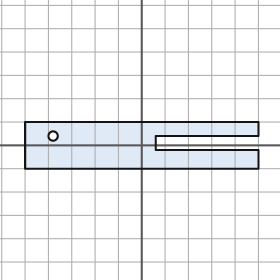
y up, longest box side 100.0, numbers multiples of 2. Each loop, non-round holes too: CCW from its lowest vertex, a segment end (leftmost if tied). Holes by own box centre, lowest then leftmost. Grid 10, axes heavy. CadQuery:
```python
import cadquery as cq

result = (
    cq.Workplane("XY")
    .moveTo(-50.0, -10.0)
    .lineTo(50.0, -10.0)
    .lineTo(50.0, -2.0)
    .lineTo(6.0, -2.0)
    .lineTo(6.0, 4.0)
    .lineTo(50.0, 4.0)
    .lineTo(50.0, 10.0)
    .lineTo(-50.0, 10.0)
    .close()
    .moveTo(-38.0, 4.0)
    .circle(2.0)
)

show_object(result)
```